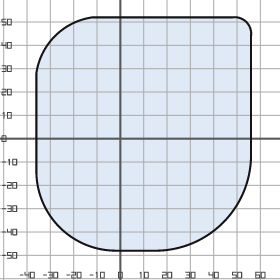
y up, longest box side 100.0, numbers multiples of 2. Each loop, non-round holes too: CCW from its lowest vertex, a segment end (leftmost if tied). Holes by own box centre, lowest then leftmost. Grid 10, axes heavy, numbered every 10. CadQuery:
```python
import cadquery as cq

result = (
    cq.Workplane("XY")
    .moveTo(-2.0, -48.0)
    .lineTo(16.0, -48.0)
    .threePointArc((44.0, -36.0), (56.0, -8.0))
    .lineTo(56.0, 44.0)
    .threePointArc((54.0, 50.0), (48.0, 52.0))
    .lineTo(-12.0, 52.0)
    .threePointArc((-28.0, 44.0), (-36.0, 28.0))
    .lineTo(-36.0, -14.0)
    .threePointArc((-26.0, -38.0), (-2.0, -48.0))
    .close()
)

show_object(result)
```